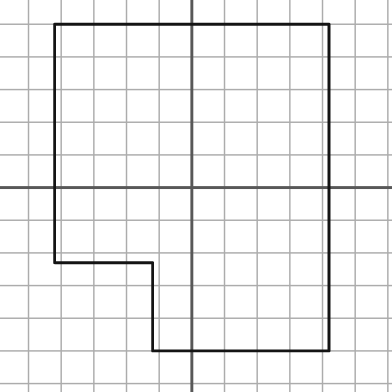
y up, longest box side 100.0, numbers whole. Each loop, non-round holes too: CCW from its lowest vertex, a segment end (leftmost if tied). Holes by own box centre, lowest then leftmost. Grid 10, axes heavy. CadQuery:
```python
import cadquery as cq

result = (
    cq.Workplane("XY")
    .moveTo(-12.0, -50.0)
    .lineTo(42.0, -50.0)
    .lineTo(42.0, 50.0)
    .lineTo(-42.0, 50.0)
    .lineTo(-42.0, -23.0)
    .lineTo(-12.0, -23.0)
    .close()
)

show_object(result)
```